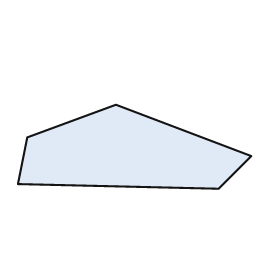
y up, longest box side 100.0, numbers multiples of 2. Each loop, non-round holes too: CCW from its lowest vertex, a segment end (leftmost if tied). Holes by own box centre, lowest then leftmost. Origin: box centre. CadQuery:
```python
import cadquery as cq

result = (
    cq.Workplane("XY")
    .moveTo(36.0, -18.0)
    .lineTo(50.0, -4.0)
    .lineTo(-8.0, 18.0)
    .lineTo(-46.0, 4.0)
    .lineTo(-50.0, -16.0)
    .close()
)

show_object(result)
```